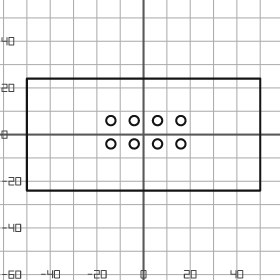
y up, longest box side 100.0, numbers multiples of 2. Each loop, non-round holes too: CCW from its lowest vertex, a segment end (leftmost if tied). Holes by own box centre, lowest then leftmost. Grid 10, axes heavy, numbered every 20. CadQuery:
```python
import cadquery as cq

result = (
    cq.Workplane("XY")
    .moveTo(-50.0, -24.0)
    .lineTo(50.0, -24.0)
    .lineTo(50.0, 24.0)
    .lineTo(-50.0, 24.0)
    .close()
    .moveTo(-14.0, -4.0)
    .circle(2.0)
    .moveTo(-4.0, -4.0)
    .circle(2.0)
    .moveTo(6.0, -4.0)
    .circle(2.0)
    .moveTo(16.0, -4.0)
    .circle(2.0)
    .moveTo(-14.0, 6.0)
    .circle(2.0)
    .moveTo(-4.0, 6.0)
    .circle(2.0)
    .moveTo(6.0, 6.0)
    .circle(2.0)
    .moveTo(16.0, 6.0)
    .circle(2.0)
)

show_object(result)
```